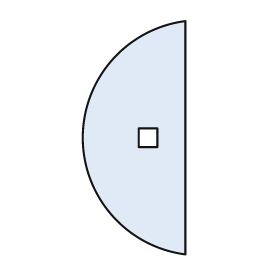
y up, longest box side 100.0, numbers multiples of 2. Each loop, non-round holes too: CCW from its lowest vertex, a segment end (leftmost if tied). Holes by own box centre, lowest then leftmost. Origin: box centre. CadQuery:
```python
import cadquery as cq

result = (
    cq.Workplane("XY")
    .moveTo(22.0, -50.0)
    .lineTo(22.0, 50.0)
    .threePointArc((-22.0, 0.0), (22.0, -50.0))
    .close()
    .moveTo(2.0, -4.0)
    .lineTo(10.0, -4.0)
    .lineTo(10.0, 4.0)
    .lineTo(2.0, 4.0)
    .close()
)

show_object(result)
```